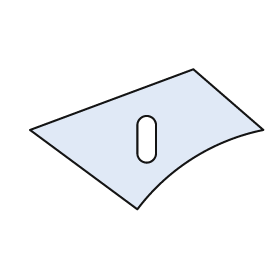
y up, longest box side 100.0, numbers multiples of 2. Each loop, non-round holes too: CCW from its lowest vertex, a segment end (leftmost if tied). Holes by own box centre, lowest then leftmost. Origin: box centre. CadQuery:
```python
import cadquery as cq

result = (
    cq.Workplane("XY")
    .moveTo(-4.0, -30.0)
    .threePointArc((20.0, -8.0), (50.0, 4.0))
    .lineTo(20.0, 30.0)
    .lineTo(-50.0, 4.0)
    .close()
    .moveTo(-4.0, -6.0)
    .threePointArc((0.0, -10.0), (4.0, -6.0))
    .lineTo(4.0, 6.0)
    .threePointArc((0.0, 10.0), (-4.0, 6.0))
    .close()
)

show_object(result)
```